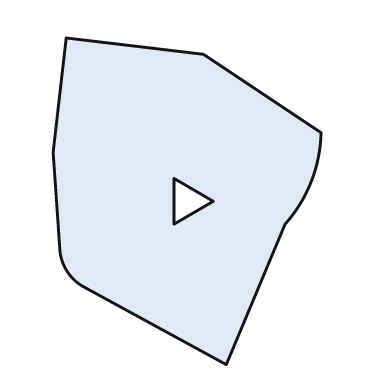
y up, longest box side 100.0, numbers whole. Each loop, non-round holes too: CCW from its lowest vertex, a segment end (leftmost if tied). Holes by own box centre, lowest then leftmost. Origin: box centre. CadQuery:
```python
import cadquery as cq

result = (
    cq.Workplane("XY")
    .moveTo(12.0, -50.0)
    .lineTo(30.0, -7.0)
    .threePointArc((38.0, 6.0), (41.0, 21.0))
    .lineTo(5.0, 45.0)
    .lineTo(-37.0, 50.0)
    .lineTo(-41.0, 15.0)
    .lineTo(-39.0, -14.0)
    .threePointArc((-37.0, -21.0), (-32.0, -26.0))
    .close()
    .moveTo(-4.0, -7.0)
    .lineTo(8.0, 0.0)
    .lineTo(-4.0, 7.0)
    .close()
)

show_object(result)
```